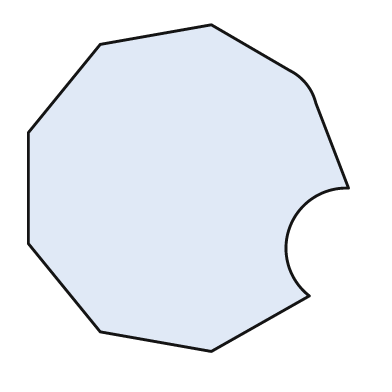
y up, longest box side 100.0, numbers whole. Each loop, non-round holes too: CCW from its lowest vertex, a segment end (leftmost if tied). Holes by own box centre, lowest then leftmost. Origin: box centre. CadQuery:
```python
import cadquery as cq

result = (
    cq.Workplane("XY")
    .moveTo(7.0, -50.0)
    .lineTo(37.0, -33.0)
    .threePointArc((31.0, -12.0), (49.0, 0.0))
    .lineTo(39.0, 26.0)
    .threePointArc((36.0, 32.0), (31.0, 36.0))
    .lineTo(7.0, 50.0)
    .lineTo(-27.0, 44.0)
    .lineTo(-49.0, 17.0)
    .lineTo(-49.0, -17.0)
    .lineTo(-27.0, -44.0)
    .close()
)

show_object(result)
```